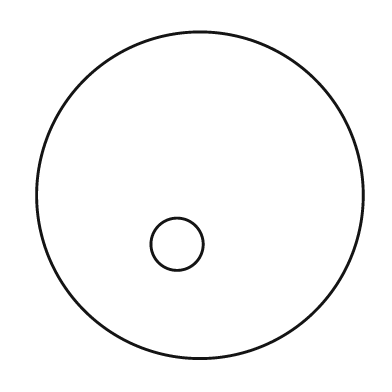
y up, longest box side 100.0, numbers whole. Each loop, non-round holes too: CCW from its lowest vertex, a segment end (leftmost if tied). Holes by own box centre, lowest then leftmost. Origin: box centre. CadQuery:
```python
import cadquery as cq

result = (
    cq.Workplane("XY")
    .moveTo(0.0, 0.0)
    .circle(50.0)
    .moveTo(-7.0, -15.0)
    .circle(8.0)
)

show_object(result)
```